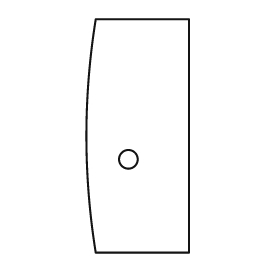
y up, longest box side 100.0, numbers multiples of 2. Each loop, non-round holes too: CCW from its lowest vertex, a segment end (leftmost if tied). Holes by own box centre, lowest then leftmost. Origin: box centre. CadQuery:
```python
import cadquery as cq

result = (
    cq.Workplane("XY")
    .moveTo(-18.0, -50.0)
    .lineTo(22.0, -50.0)
    .lineTo(22.0, 50.0)
    .lineTo(-18.0, 50.0)
    .threePointArc((-22.0, 0.0), (-18.0, -50.0))
    .close()
    .moveTo(-4.0, -10.0)
    .circle(4.0)
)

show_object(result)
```